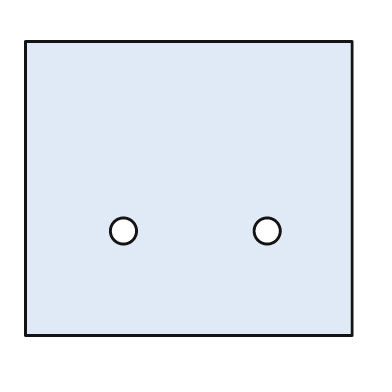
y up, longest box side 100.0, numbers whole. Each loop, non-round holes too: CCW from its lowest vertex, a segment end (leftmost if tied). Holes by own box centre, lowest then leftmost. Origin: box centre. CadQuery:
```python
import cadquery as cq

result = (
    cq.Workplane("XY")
    .moveTo(-50.0, -45.0)
    .lineTo(50.0, -45.0)
    .lineTo(50.0, 45.0)
    .lineTo(-50.0, 45.0)
    .close()
    .moveTo(-20.0, -13.0)
    .circle(4.0)
    .moveTo(24.0, -13.0)
    .circle(4.0)
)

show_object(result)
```